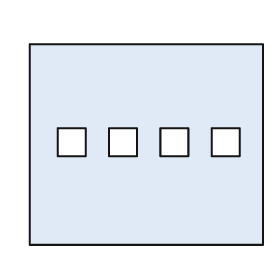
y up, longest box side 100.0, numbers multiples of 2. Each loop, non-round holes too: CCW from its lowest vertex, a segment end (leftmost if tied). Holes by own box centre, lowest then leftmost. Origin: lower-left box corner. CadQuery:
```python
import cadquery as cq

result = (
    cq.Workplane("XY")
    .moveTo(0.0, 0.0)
    .lineTo(100.0, 0.0)
    .lineTo(100.0, 86.0)
    .lineTo(0.0, 86.0)
    .close()
    .moveTo(12.0, 38.0)
    .lineTo(24.0, 38.0)
    .lineTo(24.0, 50.0)
    .lineTo(12.0, 50.0)
    .close()
    .moveTo(34.0, 38.0)
    .lineTo(46.0, 38.0)
    .lineTo(46.0, 50.0)
    .lineTo(34.0, 50.0)
    .close()
    .moveTo(56.0, 38.0)
    .lineTo(68.0, 38.0)
    .lineTo(68.0, 50.0)
    .lineTo(56.0, 50.0)
    .close()
    .moveTo(78.0, 38.0)
    .lineTo(90.0, 38.0)
    .lineTo(90.0, 50.0)
    .lineTo(78.0, 50.0)
    .close()
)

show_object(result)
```